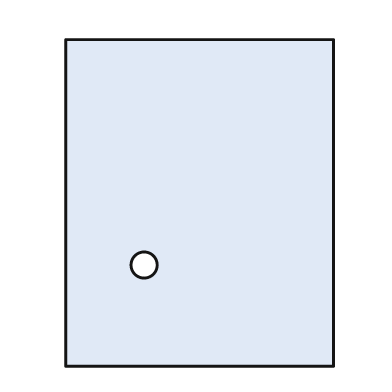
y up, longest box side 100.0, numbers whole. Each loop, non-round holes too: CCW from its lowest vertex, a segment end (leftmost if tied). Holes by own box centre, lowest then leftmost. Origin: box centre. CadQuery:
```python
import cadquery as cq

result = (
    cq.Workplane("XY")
    .moveTo(-41.0, -50.0)
    .lineTo(41.0, -50.0)
    .lineTo(41.0, 50.0)
    .lineTo(-41.0, 50.0)
    .close()
    .moveTo(-17.0, -19.0)
    .circle(4.0)
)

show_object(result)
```